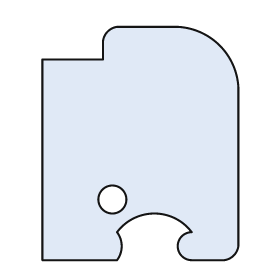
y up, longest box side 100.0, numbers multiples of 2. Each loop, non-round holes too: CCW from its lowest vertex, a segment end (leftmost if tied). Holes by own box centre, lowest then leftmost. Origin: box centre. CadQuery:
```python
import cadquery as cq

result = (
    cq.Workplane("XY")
    .moveTo(-42.0, -50.0)
    .lineTo(-10.0, -50.0)
    .threePointArc((-8.0, -44.0), (-10.0, -38.0))
    .threePointArc((6.0, -30.0), (22.0, -38.0))
    .threePointArc((16.0, -44.0), (22.0, -50.0))
    .lineTo(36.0, -50.0)
    .threePointArc((40.0, -48.0), (42.0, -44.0))
    .lineTo(42.0, 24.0)
    .threePointArc((34.0, 42.0), (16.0, 50.0))
    .lineTo(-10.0, 50.0)
    .threePointArc((-14.0, 48.0), (-16.0, 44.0))
    .lineTo(-16.0, 36.0)
    .lineTo(-42.0, 36.0)
    .close()
    .moveTo(-12.0, -24.0)
    .circle(6.0)
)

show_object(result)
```